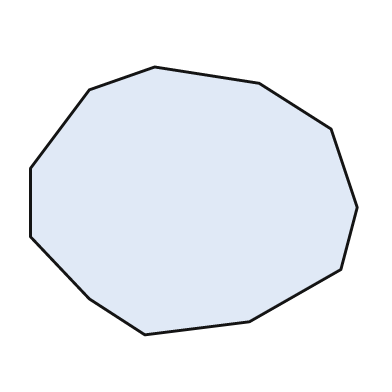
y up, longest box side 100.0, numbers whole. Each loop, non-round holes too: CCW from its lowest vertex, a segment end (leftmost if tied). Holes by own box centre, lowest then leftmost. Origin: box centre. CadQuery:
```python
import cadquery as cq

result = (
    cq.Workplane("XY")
    .moveTo(-15.0, -41.0)
    .lineTo(17.0, -37.0)
    .lineTo(45.0, -21.0)
    .lineTo(50.0, -2.0)
    .lineTo(42.0, 22.0)
    .lineTo(20.0, 36.0)
    .lineTo(-12.0, 41.0)
    .lineTo(-32.0, 34.0)
    .lineTo(-50.0, 10.0)
    .lineTo(-50.0, -11.0)
    .lineTo(-32.0, -30.0)
    .close()
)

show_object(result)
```